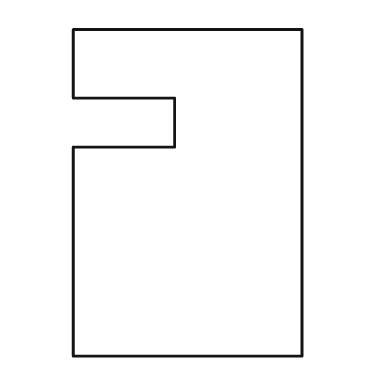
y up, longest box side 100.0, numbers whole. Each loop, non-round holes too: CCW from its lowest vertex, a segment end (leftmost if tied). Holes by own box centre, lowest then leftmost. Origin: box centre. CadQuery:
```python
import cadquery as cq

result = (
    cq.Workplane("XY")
    .moveTo(-35.0, -50.0)
    .lineTo(35.0, -50.0)
    .lineTo(35.0, 50.0)
    .lineTo(-35.0, 50.0)
    .lineTo(-35.0, 29.0)
    .lineTo(-4.0, 29.0)
    .lineTo(-4.0, 14.0)
    .lineTo(-35.0, 14.0)
    .close()
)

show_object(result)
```